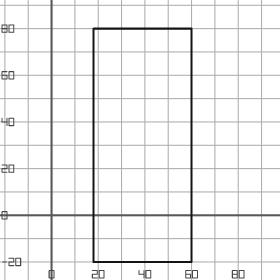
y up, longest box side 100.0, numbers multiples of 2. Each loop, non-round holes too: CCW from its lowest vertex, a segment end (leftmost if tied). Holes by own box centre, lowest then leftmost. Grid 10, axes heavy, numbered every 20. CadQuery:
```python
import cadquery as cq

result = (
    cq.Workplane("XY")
    .moveTo(18.0, -20.0)
    .lineTo(60.0, -20.0)
    .lineTo(60.0, 80.0)
    .lineTo(18.0, 80.0)
    .close()
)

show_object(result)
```